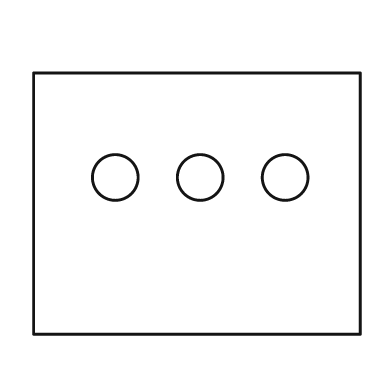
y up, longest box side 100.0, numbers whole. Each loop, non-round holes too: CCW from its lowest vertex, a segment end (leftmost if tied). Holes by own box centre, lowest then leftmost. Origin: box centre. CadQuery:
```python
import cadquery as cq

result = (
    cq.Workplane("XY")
    .moveTo(-50.0, -40.0)
    .lineTo(50.0, -40.0)
    .lineTo(50.0, 40.0)
    .lineTo(-50.0, 40.0)
    .close()
    .moveTo(-25.0, 8.0)
    .circle(7.0)
    .moveTo(1.0, 8.0)
    .circle(7.0)
    .moveTo(27.0, 8.0)
    .circle(7.0)
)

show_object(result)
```